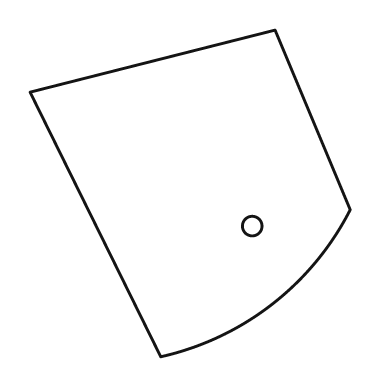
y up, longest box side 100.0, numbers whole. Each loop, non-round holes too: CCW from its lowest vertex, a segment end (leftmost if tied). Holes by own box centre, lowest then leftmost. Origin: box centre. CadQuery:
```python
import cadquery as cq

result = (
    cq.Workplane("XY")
    .moveTo(-9.0, -50.0)
    .threePointArc((25.0, -34.0), (49.0, -5.0))
    .lineTo(26.0, 50.0)
    .lineTo(-49.0, 31.0)
    .close()
    .moveTo(19.0, -10.0)
    .circle(3.0)
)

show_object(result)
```